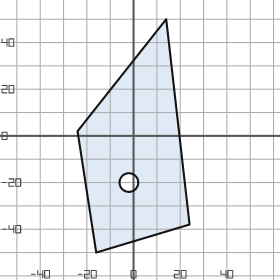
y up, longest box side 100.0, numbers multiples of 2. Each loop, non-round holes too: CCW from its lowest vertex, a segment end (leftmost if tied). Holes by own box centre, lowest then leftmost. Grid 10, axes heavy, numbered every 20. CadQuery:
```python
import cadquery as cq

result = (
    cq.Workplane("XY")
    .moveTo(-16.0, -50.0)
    .lineTo(24.0, -38.0)
    .lineTo(14.0, 50.0)
    .lineTo(-24.0, 2.0)
    .close()
    .moveTo(-2.0, -20.0)
    .circle(4.0)
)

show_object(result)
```